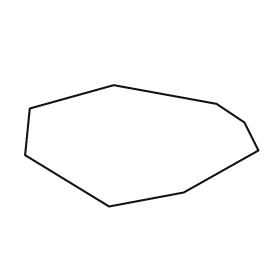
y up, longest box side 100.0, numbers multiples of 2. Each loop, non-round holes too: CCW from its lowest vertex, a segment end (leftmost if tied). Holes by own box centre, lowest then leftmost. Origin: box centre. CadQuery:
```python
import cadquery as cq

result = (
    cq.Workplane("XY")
    .moveTo(-14.0, -26.0)
    .lineTo(18.0, -20.0)
    .lineTo(50.0, -2.0)
    .lineTo(44.0, 10.0)
    .lineTo(32.0, 18.0)
    .lineTo(-12.0, 26.0)
    .lineTo(-48.0, 16.0)
    .lineTo(-50.0, -4.0)
    .close()
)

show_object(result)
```